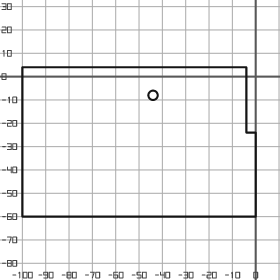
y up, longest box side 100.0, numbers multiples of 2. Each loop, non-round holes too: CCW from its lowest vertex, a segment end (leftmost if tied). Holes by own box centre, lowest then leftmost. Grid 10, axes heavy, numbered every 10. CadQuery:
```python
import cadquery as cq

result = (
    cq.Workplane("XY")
    .moveTo(-100.0, -60.0)
    .lineTo(0.0, -60.0)
    .lineTo(0.0, -24.0)
    .lineTo(-4.0, -24.0)
    .lineTo(-4.0, 4.0)
    .lineTo(-100.0, 4.0)
    .close()
    .moveTo(-44.0, -8.0)
    .circle(2.0)
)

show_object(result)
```